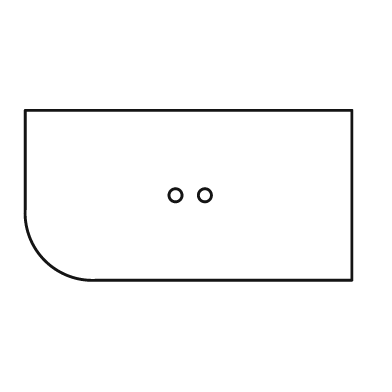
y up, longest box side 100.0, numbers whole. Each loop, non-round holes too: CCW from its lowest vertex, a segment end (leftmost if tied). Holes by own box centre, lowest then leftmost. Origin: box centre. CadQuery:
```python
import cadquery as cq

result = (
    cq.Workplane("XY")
    .moveTo(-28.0, -26.0)
    .lineTo(50.0, -26.0)
    .lineTo(50.0, 26.0)
    .lineTo(-50.0, 26.0)
    .lineTo(-50.0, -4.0)
    .threePointArc((-44.0, -20.0), (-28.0, -26.0))
    .close()
    .moveTo(-4.0, 0.0)
    .circle(2.0)
    .moveTo(5.0, 0.0)
    .circle(2.0)
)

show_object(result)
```